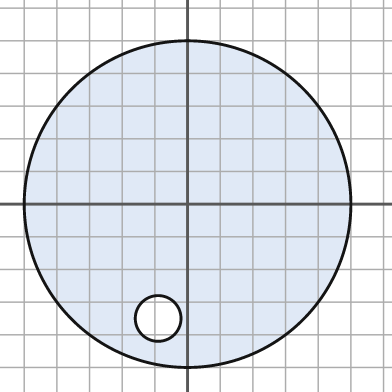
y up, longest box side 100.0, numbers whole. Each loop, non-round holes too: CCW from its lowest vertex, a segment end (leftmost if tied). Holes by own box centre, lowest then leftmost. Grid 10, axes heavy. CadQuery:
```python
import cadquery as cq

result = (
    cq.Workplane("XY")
    .moveTo(0.0, 0.0)
    .circle(50.0)
    .moveTo(-9.0, -35.0)
    .circle(7.0)
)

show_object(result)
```